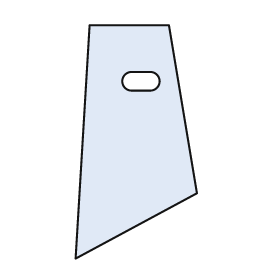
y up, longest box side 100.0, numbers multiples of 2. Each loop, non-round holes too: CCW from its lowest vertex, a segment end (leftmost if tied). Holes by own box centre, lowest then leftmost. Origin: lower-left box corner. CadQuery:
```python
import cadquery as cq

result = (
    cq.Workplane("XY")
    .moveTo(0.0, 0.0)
    .lineTo(52.0, 28.0)
    .lineTo(40.0, 100.0)
    .lineTo(6.0, 100.0)
    .close()
    .moveTo(24.0, 72.0)
    .lineTo(32.0, 72.0)
    .threePointArc((36.0, 76.0), (32.0, 80.0))
    .lineTo(24.0, 80.0)
    .threePointArc((20.0, 76.0), (24.0, 72.0))
    .close()
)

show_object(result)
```